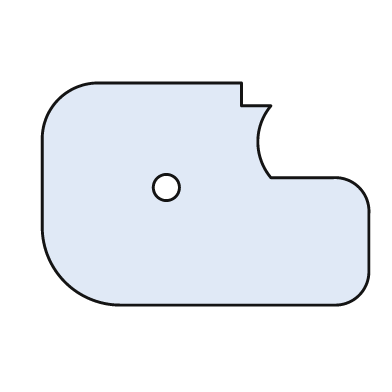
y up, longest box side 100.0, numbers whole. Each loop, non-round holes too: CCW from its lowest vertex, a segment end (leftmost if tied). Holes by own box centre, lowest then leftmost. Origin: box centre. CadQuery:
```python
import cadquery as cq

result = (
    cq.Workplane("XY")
    .moveTo(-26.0, -34.0)
    .lineTo(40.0, -34.0)
    .threePointArc((47.0, -31.0), (50.0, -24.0))
    .lineTo(50.0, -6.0)
    .threePointArc((47.0, 2.0), (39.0, 5.0))
    .lineTo(20.0, 5.0)
    .threePointArc((16.0, 16.0), (20.0, 27.0))
    .lineTo(11.0, 27.0)
    .lineTo(11.0, 34.0)
    .lineTo(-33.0, 34.0)
    .threePointArc((-45.0, 29.0), (-50.0, 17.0))
    .lineTo(-50.0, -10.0)
    .threePointArc((-43.0, -27.0), (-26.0, -34.0))
    .close()
    .moveTo(-12.0, 2.0)
    .circle(4.0)
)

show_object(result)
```